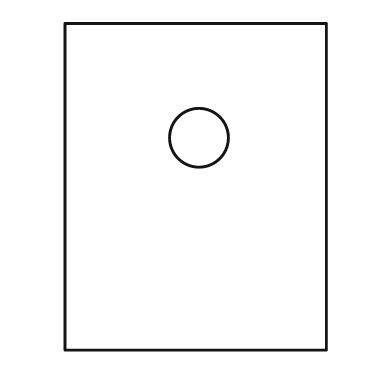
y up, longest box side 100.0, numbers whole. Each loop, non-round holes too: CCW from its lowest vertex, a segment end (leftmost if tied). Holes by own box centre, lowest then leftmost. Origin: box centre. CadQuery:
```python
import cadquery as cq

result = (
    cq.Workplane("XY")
    .moveTo(-40.0, -50.0)
    .lineTo(40.0, -50.0)
    .lineTo(40.0, 50.0)
    .lineTo(-40.0, 50.0)
    .close()
    .moveTo(1.0, 15.0)
    .circle(9.0)
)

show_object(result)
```